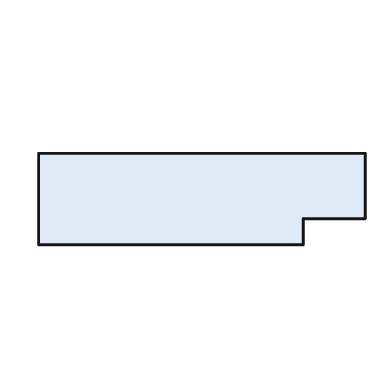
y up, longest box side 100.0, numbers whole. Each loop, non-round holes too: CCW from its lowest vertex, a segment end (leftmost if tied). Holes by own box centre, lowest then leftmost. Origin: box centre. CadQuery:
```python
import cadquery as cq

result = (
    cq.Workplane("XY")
    .moveTo(-50.0, -14.0)
    .lineTo(31.0, -14.0)
    .lineTo(31.0, -6.0)
    .lineTo(50.0, -6.0)
    .lineTo(50.0, 14.0)
    .lineTo(-50.0, 14.0)
    .close()
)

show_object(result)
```